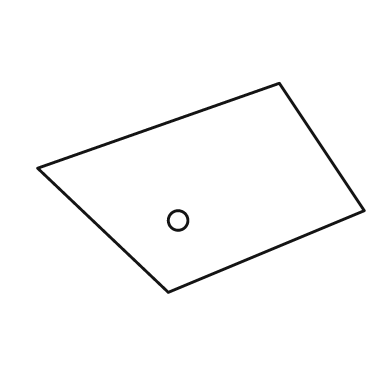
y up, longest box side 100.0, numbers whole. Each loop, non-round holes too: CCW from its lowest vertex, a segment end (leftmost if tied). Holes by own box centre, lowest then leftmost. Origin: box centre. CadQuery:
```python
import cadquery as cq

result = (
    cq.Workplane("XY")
    .moveTo(-10.0, -32.0)
    .lineTo(50.0, -7.0)
    .lineTo(24.0, 32.0)
    .lineTo(-50.0, 6.0)
    .close()
    .moveTo(-7.0, -10.0)
    .circle(3.0)
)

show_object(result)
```